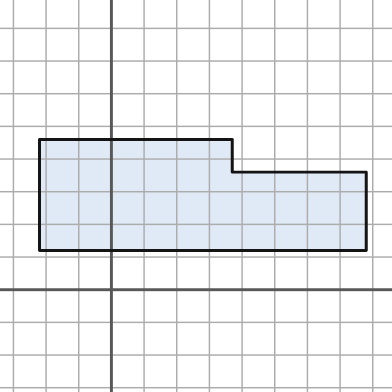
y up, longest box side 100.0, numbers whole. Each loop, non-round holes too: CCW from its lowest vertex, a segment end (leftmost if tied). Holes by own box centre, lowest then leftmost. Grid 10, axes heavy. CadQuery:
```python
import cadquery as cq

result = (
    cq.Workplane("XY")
    .moveTo(-22.0, 12.0)
    .lineTo(78.0, 12.0)
    .lineTo(78.0, 36.0)
    .lineTo(37.0, 36.0)
    .lineTo(37.0, 46.0)
    .lineTo(-22.0, 46.0)
    .close()
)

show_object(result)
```